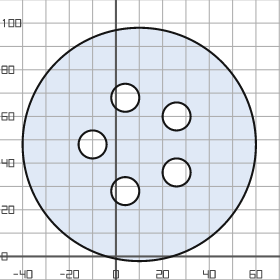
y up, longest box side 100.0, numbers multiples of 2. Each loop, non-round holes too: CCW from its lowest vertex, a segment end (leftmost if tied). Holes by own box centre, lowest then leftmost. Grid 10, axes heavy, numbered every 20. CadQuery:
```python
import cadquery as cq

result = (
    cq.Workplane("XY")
    .moveTo(10.0, 48.0)
    .circle(50.0)
    .moveTo(4.0, 28.0)
    .circle(6.0)
    .moveTo(26.0, 36.0)
    .circle(6.0)
    .moveTo(-10.0, 48.0)
    .circle(6.0)
    .moveTo(26.0, 60.0)
    .circle(6.0)
    .moveTo(4.0, 68.0)
    .circle(6.0)
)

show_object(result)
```